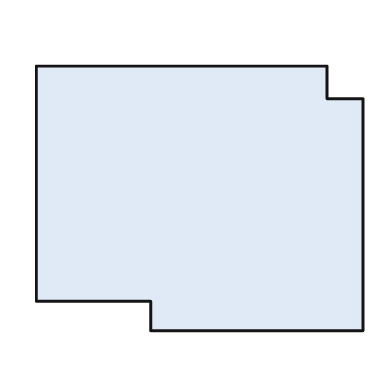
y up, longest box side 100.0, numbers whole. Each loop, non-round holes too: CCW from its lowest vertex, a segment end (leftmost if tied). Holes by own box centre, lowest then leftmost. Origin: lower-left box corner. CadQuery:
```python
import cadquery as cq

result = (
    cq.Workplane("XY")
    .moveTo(35.0, 0.0)
    .lineTo(100.0, 0.0)
    .lineTo(100.0, 71.0)
    .lineTo(89.0, 71.0)
    .lineTo(89.0, 81.0)
    .lineTo(0.0, 81.0)
    .lineTo(0.0, 9.0)
    .lineTo(35.0, 9.0)
    .close()
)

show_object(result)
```